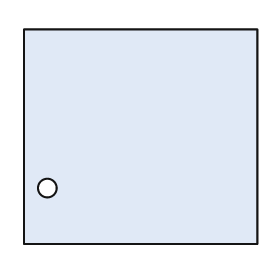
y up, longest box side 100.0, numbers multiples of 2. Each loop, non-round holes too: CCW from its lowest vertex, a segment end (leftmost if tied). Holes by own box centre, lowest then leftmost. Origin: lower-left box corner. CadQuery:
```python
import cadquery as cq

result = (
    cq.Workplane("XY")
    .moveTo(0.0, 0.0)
    .lineTo(100.0, 0.0)
    .lineTo(100.0, 92.0)
    .lineTo(0.0, 92.0)
    .close()
    .moveTo(10.0, 24.0)
    .circle(4.0)
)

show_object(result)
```